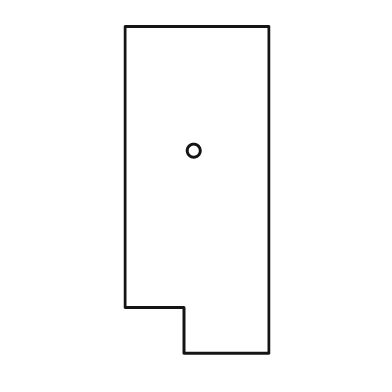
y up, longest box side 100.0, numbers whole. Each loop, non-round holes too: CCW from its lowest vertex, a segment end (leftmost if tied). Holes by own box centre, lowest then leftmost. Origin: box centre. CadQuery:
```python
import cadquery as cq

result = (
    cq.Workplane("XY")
    .moveTo(-4.0, -50.0)
    .lineTo(22.0, -50.0)
    .lineTo(22.0, 50.0)
    .lineTo(-22.0, 50.0)
    .lineTo(-22.0, -36.0)
    .lineTo(-4.0, -36.0)
    .close()
    .moveTo(-1.0, 12.0)
    .circle(2.0)
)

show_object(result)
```